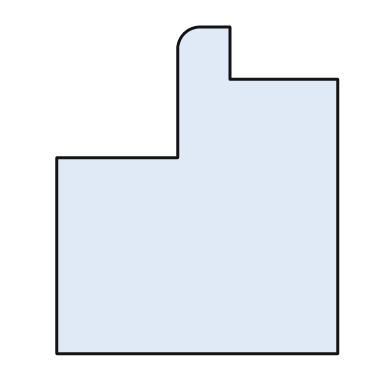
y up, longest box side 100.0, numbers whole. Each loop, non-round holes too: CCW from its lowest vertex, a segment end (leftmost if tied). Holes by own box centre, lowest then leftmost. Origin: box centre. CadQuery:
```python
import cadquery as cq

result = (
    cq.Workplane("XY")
    .moveTo(-43.0, -50.0)
    .lineTo(43.0, -50.0)
    .lineTo(43.0, 34.0)
    .lineTo(10.0, 34.0)
    .lineTo(10.0, 50.0)
    .lineTo(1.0, 50.0)
    .threePointArc((-4.0, 48.0), (-6.0, 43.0))
    .lineTo(-6.0, 10.0)
    .lineTo(-43.0, 10.0)
    .close()
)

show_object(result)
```